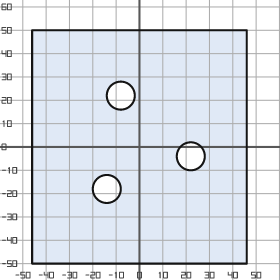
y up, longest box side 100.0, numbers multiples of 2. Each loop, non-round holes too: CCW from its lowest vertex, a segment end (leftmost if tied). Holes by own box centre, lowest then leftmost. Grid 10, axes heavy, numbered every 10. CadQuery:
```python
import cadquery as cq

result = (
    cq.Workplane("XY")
    .moveTo(-46.0, -50.0)
    .lineTo(46.0, -50.0)
    .lineTo(46.0, 50.0)
    .lineTo(-46.0, 50.0)
    .close()
    .moveTo(-14.0, -18.0)
    .circle(6.0)
    .moveTo(22.0, -4.0)
    .circle(6.0)
    .moveTo(-8.0, 22.0)
    .circle(6.0)
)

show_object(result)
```